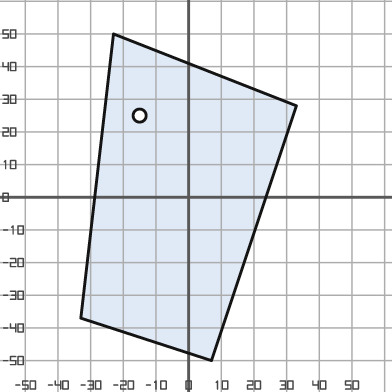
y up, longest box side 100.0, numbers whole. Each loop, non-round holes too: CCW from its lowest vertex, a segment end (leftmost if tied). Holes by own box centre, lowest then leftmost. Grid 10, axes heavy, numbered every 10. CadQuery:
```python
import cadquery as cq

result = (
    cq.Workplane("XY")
    .moveTo(7.0, -50.0)
    .lineTo(33.0, 28.0)
    .lineTo(-23.0, 50.0)
    .lineTo(-33.0, -37.0)
    .close()
    .moveTo(-15.0, 25.0)
    .circle(2.0)
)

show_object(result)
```